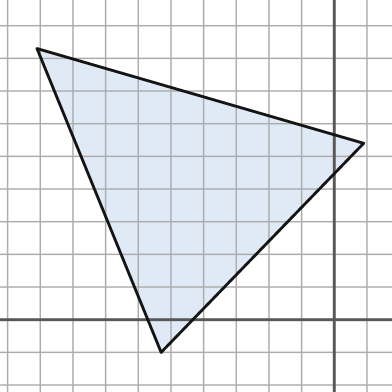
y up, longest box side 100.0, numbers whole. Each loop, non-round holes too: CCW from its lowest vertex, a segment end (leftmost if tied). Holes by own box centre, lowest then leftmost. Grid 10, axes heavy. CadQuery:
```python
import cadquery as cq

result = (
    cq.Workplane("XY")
    .moveTo(-53.0, -10.0)
    .lineTo(9.0, 54.0)
    .lineTo(-91.0, 83.0)
    .close()
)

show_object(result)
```